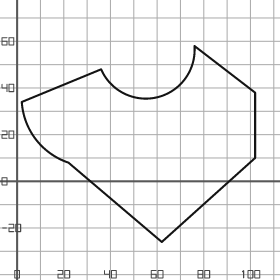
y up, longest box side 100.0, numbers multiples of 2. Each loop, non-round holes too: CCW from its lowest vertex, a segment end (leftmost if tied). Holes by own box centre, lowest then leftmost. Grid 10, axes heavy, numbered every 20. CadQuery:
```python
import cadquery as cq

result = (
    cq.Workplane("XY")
    .moveTo(62.0, -26.0)
    .lineTo(102.0, 10.0)
    .lineTo(102.0, 38.0)
    .lineTo(76.0, 58.0)
    .threePointArc((60.0, 36.0), (36.0, 48.0))
    .lineTo(2.0, 34.0)
    .threePointArc((8.0, 18.0), (22.0, 8.0))
    .close()
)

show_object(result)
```